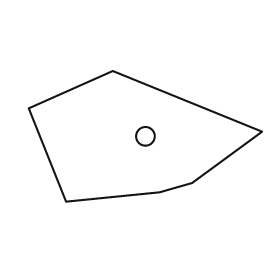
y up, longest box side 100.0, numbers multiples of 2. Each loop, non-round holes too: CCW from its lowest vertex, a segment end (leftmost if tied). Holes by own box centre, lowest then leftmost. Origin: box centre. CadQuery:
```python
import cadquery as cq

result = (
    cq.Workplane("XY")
    .moveTo(-34.0, -28.0)
    .lineTo(6.0, -24.0)
    .lineTo(20.0, -20.0)
    .lineTo(50.0, 2.0)
    .lineTo(-14.0, 28.0)
    .lineTo(-50.0, 12.0)
    .close()
    .moveTo(0.0, 0.0)
    .circle(4.0)
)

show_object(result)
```